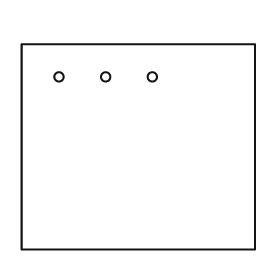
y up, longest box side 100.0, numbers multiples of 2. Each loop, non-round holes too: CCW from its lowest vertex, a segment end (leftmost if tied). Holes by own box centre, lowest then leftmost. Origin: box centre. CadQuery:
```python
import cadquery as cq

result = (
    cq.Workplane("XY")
    .moveTo(-50.0, -44.0)
    .lineTo(50.0, -44.0)
    .lineTo(50.0, 44.0)
    .lineTo(-50.0, 44.0)
    .close()
    .moveTo(-34.0, 30.0)
    .circle(2.0)
    .moveTo(-14.0, 30.0)
    .circle(2.0)
    .moveTo(6.0, 30.0)
    .circle(2.0)
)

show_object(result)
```